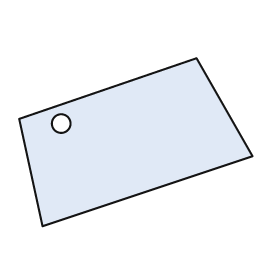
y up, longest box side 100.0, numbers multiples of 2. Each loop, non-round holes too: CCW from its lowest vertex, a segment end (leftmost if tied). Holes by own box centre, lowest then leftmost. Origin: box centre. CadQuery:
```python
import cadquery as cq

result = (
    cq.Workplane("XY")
    .moveTo(-40.0, -36.0)
    .lineTo(50.0, -6.0)
    .lineTo(26.0, 36.0)
    .lineTo(-50.0, 10.0)
    .close()
    .moveTo(-32.0, 8.0)
    .circle(4.0)
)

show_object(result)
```